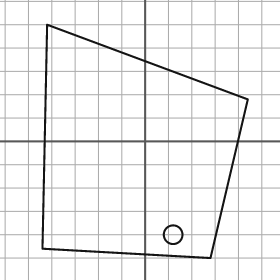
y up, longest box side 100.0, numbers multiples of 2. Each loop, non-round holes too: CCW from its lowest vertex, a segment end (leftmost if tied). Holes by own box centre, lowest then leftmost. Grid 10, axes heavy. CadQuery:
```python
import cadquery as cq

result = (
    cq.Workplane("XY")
    .moveTo(28.0, -50.0)
    .lineTo(44.0, 18.0)
    .lineTo(-42.0, 50.0)
    .lineTo(-44.0, -46.0)
    .close()
    .moveTo(12.0, -40.0)
    .circle(4.0)
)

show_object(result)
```